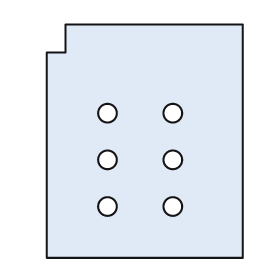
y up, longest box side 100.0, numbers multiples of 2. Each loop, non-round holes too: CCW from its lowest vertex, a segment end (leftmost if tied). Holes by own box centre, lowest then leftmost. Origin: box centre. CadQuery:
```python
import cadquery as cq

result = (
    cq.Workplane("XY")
    .moveTo(-42.0, -50.0)
    .lineTo(42.0, -50.0)
    .lineTo(42.0, 50.0)
    .lineTo(-34.0, 50.0)
    .lineTo(-34.0, 38.0)
    .lineTo(-42.0, 38.0)
    .close()
    .moveTo(-16.0, -28.0)
    .circle(4.0)
    .moveTo(12.0, -28.0)
    .circle(4.0)
    .moveTo(-16.0, -8.0)
    .circle(4.0)
    .moveTo(12.0, -8.0)
    .circle(4.0)
    .moveTo(-16.0, 12.0)
    .circle(4.0)
    .moveTo(12.0, 12.0)
    .circle(4.0)
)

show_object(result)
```